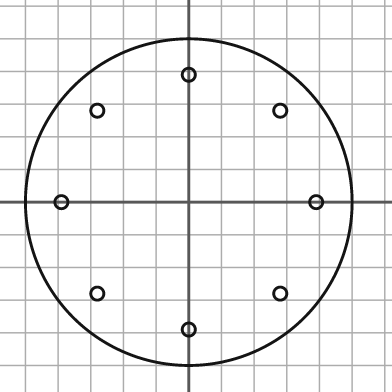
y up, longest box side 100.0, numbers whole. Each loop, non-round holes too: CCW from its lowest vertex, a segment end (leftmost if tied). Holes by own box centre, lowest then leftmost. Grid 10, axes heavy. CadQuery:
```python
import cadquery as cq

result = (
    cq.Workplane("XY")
    .moveTo(0.0, 0.0)
    .circle(50.0)
    .moveTo(0.0, -39.0)
    .circle(2.0)
    .moveTo(-28.0, -28.0)
    .circle(2.0)
    .moveTo(28.0, -28.0)
    .circle(2.0)
    .moveTo(-39.0, 0.0)
    .circle(2.0)
    .moveTo(39.0, 0.0)
    .circle(2.0)
    .moveTo(-28.0, 28.0)
    .circle(2.0)
    .moveTo(28.0, 28.0)
    .circle(2.0)
    .moveTo(0.0, 39.0)
    .circle(2.0)
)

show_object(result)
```